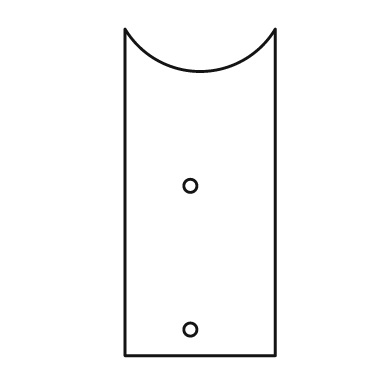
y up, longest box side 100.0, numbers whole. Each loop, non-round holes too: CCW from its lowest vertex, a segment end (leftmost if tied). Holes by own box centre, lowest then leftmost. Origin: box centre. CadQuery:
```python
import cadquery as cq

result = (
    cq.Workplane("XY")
    .moveTo(-23.0, -50.0)
    .lineTo(23.0, -50.0)
    .lineTo(23.0, 50.0)
    .threePointArc((0.0, 37.0), (-23.0, 50.0))
    .close()
    .moveTo(-3.0, -42.0)
    .circle(2.0)
    .moveTo(-3.0, 2.0)
    .circle(2.0)
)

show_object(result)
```